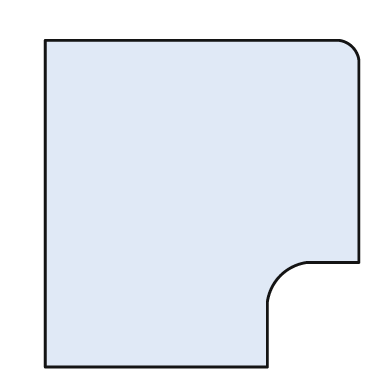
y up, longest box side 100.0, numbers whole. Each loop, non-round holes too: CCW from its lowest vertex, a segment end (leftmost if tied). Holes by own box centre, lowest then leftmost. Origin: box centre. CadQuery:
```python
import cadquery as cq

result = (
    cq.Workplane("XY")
    .moveTo(-48.0, -50.0)
    .lineTo(20.0, -50.0)
    .lineTo(20.0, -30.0)
    .threePointArc((24.0, -22.0), (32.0, -18.0))
    .lineTo(48.0, -18.0)
    .lineTo(48.0, 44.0)
    .threePointArc((46.0, 48.0), (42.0, 50.0))
    .lineTo(-48.0, 50.0)
    .close()
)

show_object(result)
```